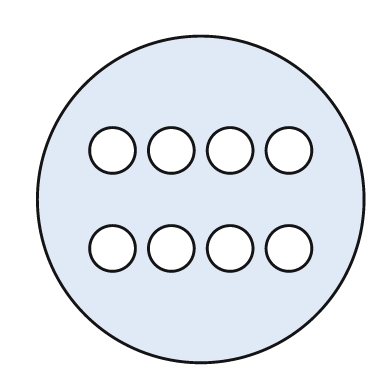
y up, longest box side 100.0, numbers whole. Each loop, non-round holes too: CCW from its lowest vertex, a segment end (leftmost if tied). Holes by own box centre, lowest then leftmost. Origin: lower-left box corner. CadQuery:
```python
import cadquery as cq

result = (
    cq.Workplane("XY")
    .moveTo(50.0, 50.0)
    .circle(50.0)
    .moveTo(23.0, 35.0)
    .circle(7.0)
    .moveTo(41.0, 35.0)
    .circle(7.0)
    .moveTo(59.0, 35.0)
    .circle(7.0)
    .moveTo(77.0, 35.0)
    .circle(7.0)
    .moveTo(23.0, 65.0)
    .circle(7.0)
    .moveTo(41.0, 65.0)
    .circle(7.0)
    .moveTo(59.0, 65.0)
    .circle(7.0)
    .moveTo(77.0, 65.0)
    .circle(7.0)
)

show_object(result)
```